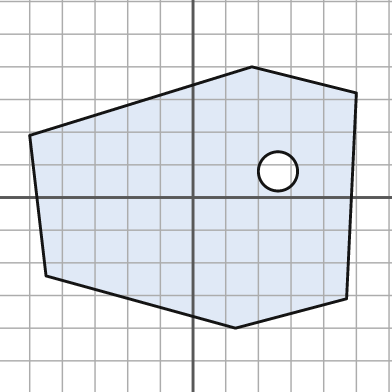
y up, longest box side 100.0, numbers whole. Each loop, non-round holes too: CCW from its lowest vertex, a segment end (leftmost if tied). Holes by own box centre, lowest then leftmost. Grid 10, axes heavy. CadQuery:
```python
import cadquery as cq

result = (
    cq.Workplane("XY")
    .moveTo(13.0, -40.0)
    .lineTo(47.0, -31.0)
    .lineTo(50.0, 32.0)
    .lineTo(18.0, 40.0)
    .lineTo(-50.0, 19.0)
    .lineTo(-45.0, -24.0)
    .close()
    .moveTo(26.0, 8.0)
    .circle(6.0)
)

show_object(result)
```